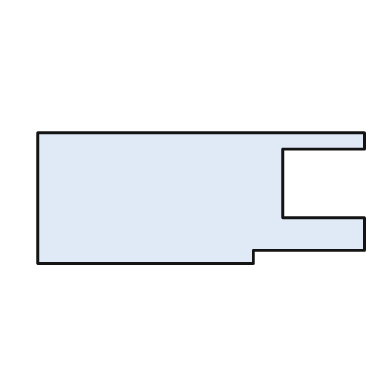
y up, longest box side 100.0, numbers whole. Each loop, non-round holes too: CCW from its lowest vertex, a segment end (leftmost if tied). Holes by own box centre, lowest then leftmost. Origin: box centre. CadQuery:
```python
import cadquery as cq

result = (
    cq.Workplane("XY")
    .moveTo(-50.0, -20.0)
    .lineTo(16.0, -20.0)
    .lineTo(16.0, -16.0)
    .lineTo(50.0, -16.0)
    .lineTo(50.0, -6.0)
    .lineTo(25.0, -6.0)
    .lineTo(25.0, 15.0)
    .lineTo(50.0, 15.0)
    .lineTo(50.0, 20.0)
    .lineTo(-50.0, 20.0)
    .close()
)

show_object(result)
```